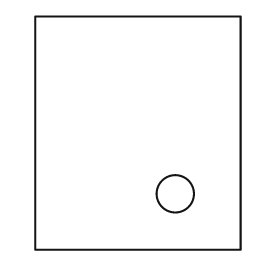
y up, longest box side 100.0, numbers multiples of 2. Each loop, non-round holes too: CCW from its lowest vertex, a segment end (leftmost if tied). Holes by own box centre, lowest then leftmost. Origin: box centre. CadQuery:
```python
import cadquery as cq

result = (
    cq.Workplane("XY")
    .moveTo(-44.0, -50.0)
    .lineTo(44.0, -50.0)
    .lineTo(44.0, 50.0)
    .lineTo(-44.0, 50.0)
    .close()
    .moveTo(16.0, -26.0)
    .circle(8.0)
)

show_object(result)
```